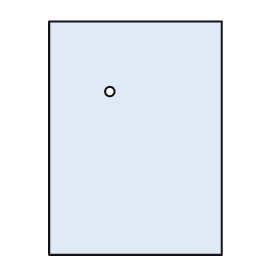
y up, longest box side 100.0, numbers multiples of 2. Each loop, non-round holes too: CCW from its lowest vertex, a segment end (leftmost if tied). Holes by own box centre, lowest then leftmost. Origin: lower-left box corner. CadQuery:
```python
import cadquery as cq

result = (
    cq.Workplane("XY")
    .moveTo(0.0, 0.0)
    .lineTo(74.0, 0.0)
    .lineTo(74.0, 100.0)
    .lineTo(0.0, 100.0)
    .close()
    .moveTo(26.0, 70.0)
    .circle(2.0)
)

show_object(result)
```